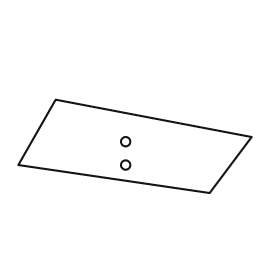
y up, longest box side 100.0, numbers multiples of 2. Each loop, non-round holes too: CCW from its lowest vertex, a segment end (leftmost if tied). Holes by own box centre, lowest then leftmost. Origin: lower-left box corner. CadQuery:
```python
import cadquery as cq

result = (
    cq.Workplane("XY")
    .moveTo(82.0, 0.0)
    .lineTo(100.0, 24.0)
    .lineTo(16.0, 40.0)
    .lineTo(0.0, 12.0)
    .close()
    .moveTo(46.0, 12.0)
    .circle(2.0)
    .moveTo(46.0, 22.0)
    .circle(2.0)
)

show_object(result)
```